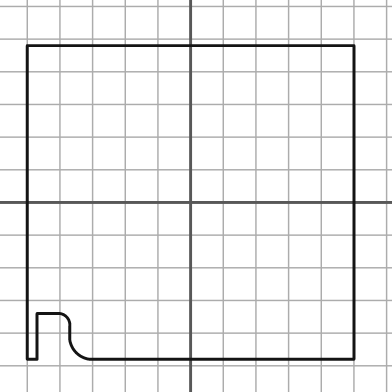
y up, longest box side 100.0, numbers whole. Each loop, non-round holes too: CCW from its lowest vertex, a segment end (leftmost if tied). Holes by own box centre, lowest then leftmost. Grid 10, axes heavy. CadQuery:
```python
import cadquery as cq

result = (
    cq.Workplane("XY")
    .moveTo(-50.0, -48.0)
    .lineTo(-47.0, -48.0)
    .lineTo(-47.0, -34.0)
    .lineTo(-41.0, -34.0)
    .threePointArc((-38.0, -35.0), (-37.0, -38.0))
    .lineTo(-37.0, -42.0)
    .threePointArc((-35.0, -46.0), (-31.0, -48.0))
    .lineTo(50.0, -48.0)
    .lineTo(50.0, 48.0)
    .lineTo(-50.0, 48.0)
    .close()
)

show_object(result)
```